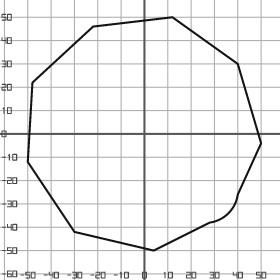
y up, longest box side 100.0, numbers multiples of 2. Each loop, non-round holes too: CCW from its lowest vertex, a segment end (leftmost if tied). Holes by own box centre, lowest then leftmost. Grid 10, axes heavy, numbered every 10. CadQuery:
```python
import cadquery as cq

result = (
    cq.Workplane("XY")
    .moveTo(4.0, -50.0)
    .lineTo(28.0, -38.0)
    .threePointArc((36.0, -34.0), (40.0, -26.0))
    .lineTo(50.0, -4.0)
    .lineTo(40.0, 30.0)
    .lineTo(12.0, 50.0)
    .lineTo(-22.0, 46.0)
    .lineTo(-48.0, 22.0)
    .lineTo(-50.0, -12.0)
    .lineTo(-30.0, -42.0)
    .close()
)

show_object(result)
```